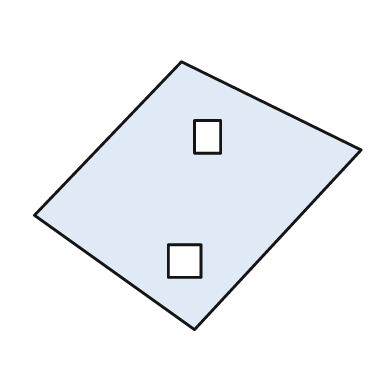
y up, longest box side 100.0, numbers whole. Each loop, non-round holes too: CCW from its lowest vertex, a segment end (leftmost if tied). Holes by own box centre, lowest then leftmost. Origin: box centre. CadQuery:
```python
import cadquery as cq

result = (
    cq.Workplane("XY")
    .moveTo(-1.0, -41.0)
    .lineTo(50.0, 14.0)
    .lineTo(-5.0, 41.0)
    .lineTo(-50.0, -6.0)
    .close()
    .moveTo(-9.0, -25.0)
    .lineTo(1.0, -25.0)
    .lineTo(1.0, -15.0)
    .lineTo(-9.0, -15.0)
    .close()
    .moveTo(-1.0, 13.0)
    .lineTo(7.0, 13.0)
    .lineTo(7.0, 23.0)
    .lineTo(-1.0, 23.0)
    .close()
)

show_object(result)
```